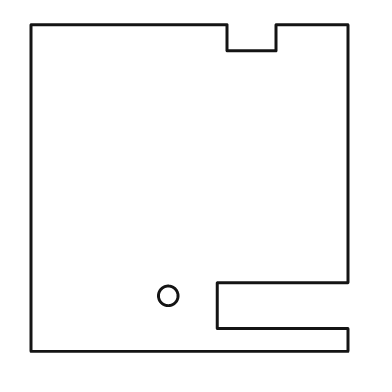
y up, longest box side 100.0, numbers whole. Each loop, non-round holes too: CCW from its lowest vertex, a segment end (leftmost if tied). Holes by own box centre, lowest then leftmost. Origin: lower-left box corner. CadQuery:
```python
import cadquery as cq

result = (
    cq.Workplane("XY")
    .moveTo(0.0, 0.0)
    .lineTo(97.0, 0.0)
    .lineTo(97.0, 7.0)
    .lineTo(57.0, 7.0)
    .lineTo(57.0, 21.0)
    .lineTo(97.0, 21.0)
    .lineTo(97.0, 100.0)
    .lineTo(75.0, 100.0)
    .lineTo(75.0, 92.0)
    .lineTo(60.0, 92.0)
    .lineTo(60.0, 100.0)
    .lineTo(0.0, 100.0)
    .close()
    .moveTo(42.0, 17.0)
    .circle(3.0)
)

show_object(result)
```